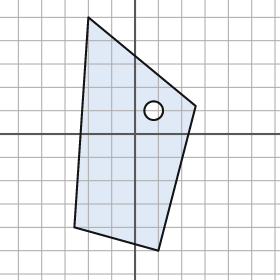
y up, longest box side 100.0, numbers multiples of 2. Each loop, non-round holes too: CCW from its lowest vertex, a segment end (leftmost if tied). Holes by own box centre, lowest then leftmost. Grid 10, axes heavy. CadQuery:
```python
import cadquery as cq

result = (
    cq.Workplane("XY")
    .moveTo(10.0, -50.0)
    .lineTo(26.0, 12.0)
    .lineTo(-20.0, 50.0)
    .lineTo(-26.0, -40.0)
    .close()
    .moveTo(8.0, 10.0)
    .circle(4.0)
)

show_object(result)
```